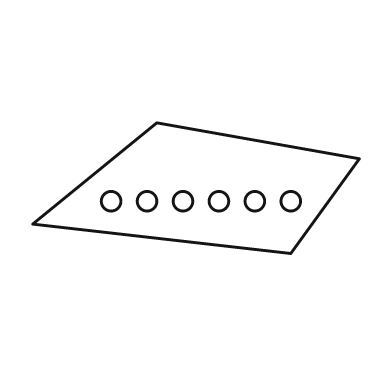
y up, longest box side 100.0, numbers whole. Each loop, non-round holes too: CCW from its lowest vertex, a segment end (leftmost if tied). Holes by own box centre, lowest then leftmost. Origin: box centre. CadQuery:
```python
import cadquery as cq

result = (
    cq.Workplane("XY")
    .moveTo(29.0, -20.0)
    .lineTo(50.0, 9.0)
    .lineTo(-12.0, 20.0)
    .lineTo(-50.0, -11.0)
    .close()
    .moveTo(-26.0, -4.0)
    .circle(3.0)
    .moveTo(-15.0, -4.0)
    .circle(3.0)
    .moveTo(-4.0, -4.0)
    .circle(3.0)
    .moveTo(7.0, -4.0)
    .circle(3.0)
    .moveTo(18.0, -4.0)
    .circle(3.0)
    .moveTo(29.0, -4.0)
    .circle(3.0)
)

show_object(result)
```